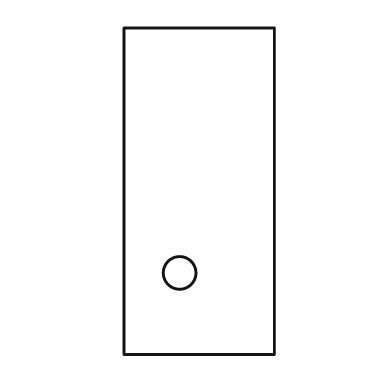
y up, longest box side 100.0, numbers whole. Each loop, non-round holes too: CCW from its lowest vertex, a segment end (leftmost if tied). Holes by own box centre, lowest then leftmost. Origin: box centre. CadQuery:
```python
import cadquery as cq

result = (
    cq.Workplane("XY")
    .moveTo(-23.0, -50.0)
    .lineTo(23.0, -50.0)
    .lineTo(23.0, 50.0)
    .lineTo(-23.0, 50.0)
    .close()
    .moveTo(-6.0, -25.0)
    .circle(5.0)
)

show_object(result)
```